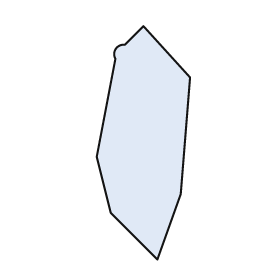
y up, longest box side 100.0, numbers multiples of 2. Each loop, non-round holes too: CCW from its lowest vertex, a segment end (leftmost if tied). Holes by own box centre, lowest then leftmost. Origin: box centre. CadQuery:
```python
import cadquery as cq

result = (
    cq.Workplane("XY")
    .moveTo(6.0, -50.0)
    .lineTo(16.0, -22.0)
    .lineTo(20.0, 28.0)
    .lineTo(0.0, 50.0)
    .lineTo(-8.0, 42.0)
    .threePointArc((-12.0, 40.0), (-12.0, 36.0))
    .lineTo(-20.0, -6.0)
    .lineTo(-14.0, -30.0)
    .close()
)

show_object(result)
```